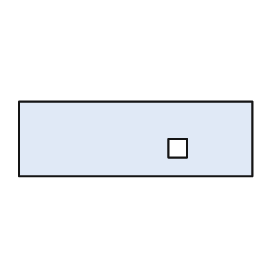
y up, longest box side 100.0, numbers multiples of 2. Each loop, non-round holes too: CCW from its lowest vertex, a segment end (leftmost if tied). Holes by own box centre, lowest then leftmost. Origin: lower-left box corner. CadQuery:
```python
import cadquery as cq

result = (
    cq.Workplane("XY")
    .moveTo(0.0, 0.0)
    .lineTo(100.0, 0.0)
    .lineTo(100.0, 32.0)
    .lineTo(0.0, 32.0)
    .close()
    .moveTo(64.0, 8.0)
    .lineTo(72.0, 8.0)
    .lineTo(72.0, 16.0)
    .lineTo(64.0, 16.0)
    .close()
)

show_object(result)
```